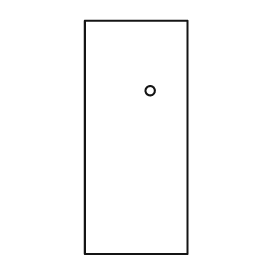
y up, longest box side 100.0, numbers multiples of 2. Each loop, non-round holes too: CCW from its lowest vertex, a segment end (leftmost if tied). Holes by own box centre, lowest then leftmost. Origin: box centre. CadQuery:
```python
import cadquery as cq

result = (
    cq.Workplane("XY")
    .moveTo(-22.0, -50.0)
    .lineTo(22.0, -50.0)
    .lineTo(22.0, 50.0)
    .lineTo(-22.0, 50.0)
    .close()
    .moveTo(6.0, 20.0)
    .circle(2.0)
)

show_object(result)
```